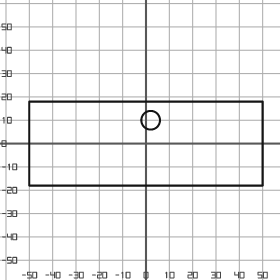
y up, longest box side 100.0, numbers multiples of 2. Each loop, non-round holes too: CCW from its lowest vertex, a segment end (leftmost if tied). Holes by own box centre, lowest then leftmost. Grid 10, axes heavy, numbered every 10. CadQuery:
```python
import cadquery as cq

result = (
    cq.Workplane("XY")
    .moveTo(-50.0, -18.0)
    .lineTo(50.0, -18.0)
    .lineTo(50.0, 18.0)
    .lineTo(-50.0, 18.0)
    .close()
    .moveTo(2.0, 10.0)
    .circle(4.0)
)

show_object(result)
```